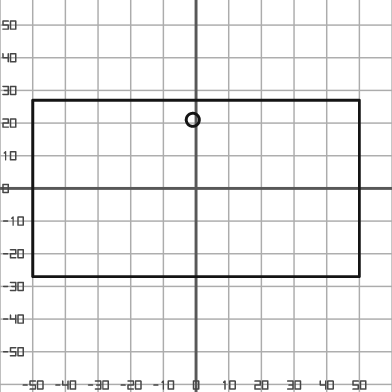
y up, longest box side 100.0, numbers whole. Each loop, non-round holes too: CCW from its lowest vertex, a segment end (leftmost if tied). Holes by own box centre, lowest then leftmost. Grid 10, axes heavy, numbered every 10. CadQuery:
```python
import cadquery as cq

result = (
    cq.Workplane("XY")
    .moveTo(-50.0, -27.0)
    .lineTo(50.0, -27.0)
    .lineTo(50.0, 27.0)
    .lineTo(-50.0, 27.0)
    .close()
    .moveTo(-1.0, 21.0)
    .circle(2.0)
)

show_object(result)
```